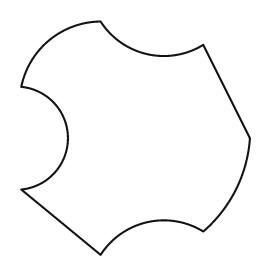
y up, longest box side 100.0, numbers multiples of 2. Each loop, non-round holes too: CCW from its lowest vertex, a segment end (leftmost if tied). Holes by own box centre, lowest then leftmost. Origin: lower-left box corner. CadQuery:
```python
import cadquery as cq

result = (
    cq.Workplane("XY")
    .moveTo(34.0, 0.0)
    .threePointArc((54.0, 14.0), (78.0, 10.0))
    .threePointArc((92.0, 28.0), (98.0, 50.0))
    .lineTo(78.0, 90.0)
    .threePointArc((54.0, 86.0), (34.0, 100.0))
    .threePointArc((12.0, 92.0), (0.0, 72.0))
    .threePointArc((20.0, 50.0), (0.0, 28.0))
    .close()
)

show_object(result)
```